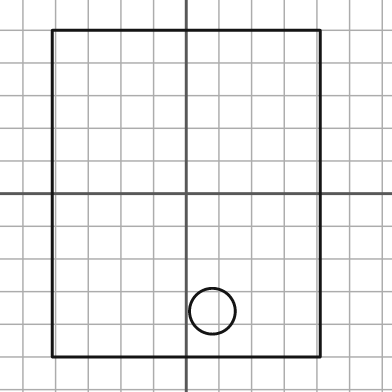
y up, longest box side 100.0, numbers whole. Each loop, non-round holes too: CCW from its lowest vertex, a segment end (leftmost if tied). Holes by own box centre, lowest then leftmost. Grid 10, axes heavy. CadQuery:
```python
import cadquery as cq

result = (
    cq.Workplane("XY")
    .moveTo(-41.0, -50.0)
    .lineTo(41.0, -50.0)
    .lineTo(41.0, 50.0)
    .lineTo(-41.0, 50.0)
    .close()
    .moveTo(8.0, -36.0)
    .circle(7.0)
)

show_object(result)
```